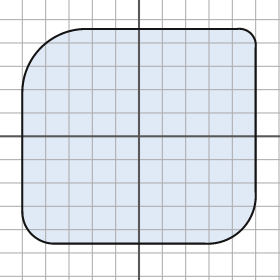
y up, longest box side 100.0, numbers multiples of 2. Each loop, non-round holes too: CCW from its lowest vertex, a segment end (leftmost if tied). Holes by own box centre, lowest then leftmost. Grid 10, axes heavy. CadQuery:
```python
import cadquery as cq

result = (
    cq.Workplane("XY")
    .moveTo(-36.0, -46.0)
    .lineTo(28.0, -46.0)
    .threePointArc((44.0, -40.0), (50.0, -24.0))
    .lineTo(50.0, 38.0)
    .threePointArc((48.0, 44.0), (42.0, 46.0))
    .lineTo(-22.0, 46.0)
    .threePointArc((-42.0, 38.0), (-50.0, 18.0))
    .lineTo(-50.0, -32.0)
    .threePointArc((-46.0, -42.0), (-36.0, -46.0))
    .close()
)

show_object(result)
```